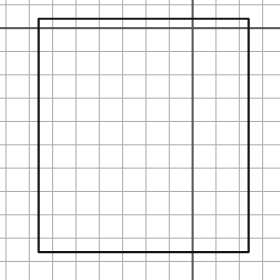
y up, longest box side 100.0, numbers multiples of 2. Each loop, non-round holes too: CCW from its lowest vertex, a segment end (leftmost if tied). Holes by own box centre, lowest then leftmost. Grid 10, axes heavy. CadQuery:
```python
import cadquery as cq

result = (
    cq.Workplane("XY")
    .moveTo(-66.0, -96.0)
    .lineTo(24.0, -96.0)
    .lineTo(24.0, 4.0)
    .lineTo(-66.0, 4.0)
    .close()
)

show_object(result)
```